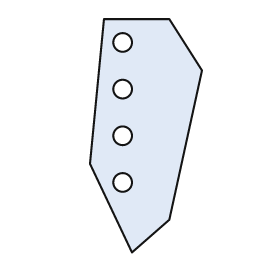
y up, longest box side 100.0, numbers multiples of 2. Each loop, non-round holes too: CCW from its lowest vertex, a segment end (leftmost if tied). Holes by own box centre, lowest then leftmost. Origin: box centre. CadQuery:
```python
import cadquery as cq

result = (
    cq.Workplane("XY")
    .moveTo(-6.0, -50.0)
    .lineTo(10.0, -36.0)
    .lineTo(24.0, 28.0)
    .lineTo(10.0, 50.0)
    .lineTo(-18.0, 50.0)
    .lineTo(-24.0, -12.0)
    .close()
    .moveTo(-10.0, -20.0)
    .circle(4.0)
    .moveTo(-10.0, 0.0)
    .circle(4.0)
    .moveTo(-10.0, 20.0)
    .circle(4.0)
    .moveTo(-10.0, 40.0)
    .circle(4.0)
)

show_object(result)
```